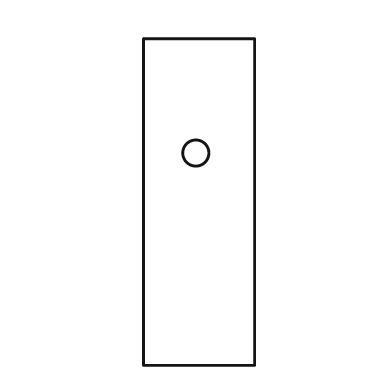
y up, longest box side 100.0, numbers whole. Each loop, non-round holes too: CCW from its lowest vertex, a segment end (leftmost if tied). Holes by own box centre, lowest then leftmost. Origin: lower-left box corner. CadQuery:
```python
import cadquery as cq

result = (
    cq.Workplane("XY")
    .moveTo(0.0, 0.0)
    .lineTo(34.0, 0.0)
    .lineTo(34.0, 100.0)
    .lineTo(0.0, 100.0)
    .close()
    .moveTo(16.0, 65.0)
    .circle(4.0)
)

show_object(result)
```